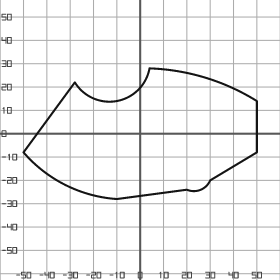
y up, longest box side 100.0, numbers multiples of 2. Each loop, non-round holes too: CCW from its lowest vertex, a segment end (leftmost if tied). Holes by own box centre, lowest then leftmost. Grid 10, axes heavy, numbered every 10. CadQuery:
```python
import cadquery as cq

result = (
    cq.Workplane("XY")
    .moveTo(-10.0, -28.0)
    .lineTo(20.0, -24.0)
    .threePointArc((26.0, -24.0), (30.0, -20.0))
    .lineTo(50.0, -8.0)
    .lineTo(50.0, 14.0)
    .threePointArc((28.0, 24.0), (4.0, 28.0))
    .threePointArc((-10.0, 14.0), (-28.0, 22.0))
    .lineTo(-50.0, -8.0)
    .threePointArc((-32.0, -22.0), (-10.0, -28.0))
    .close()
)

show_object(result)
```